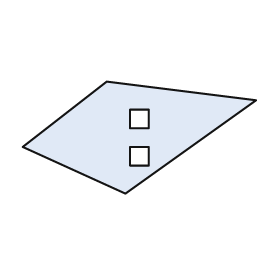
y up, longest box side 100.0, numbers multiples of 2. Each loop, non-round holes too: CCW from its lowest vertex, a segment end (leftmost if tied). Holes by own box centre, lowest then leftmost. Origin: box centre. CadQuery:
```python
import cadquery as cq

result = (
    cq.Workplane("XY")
    .moveTo(-6.0, -24.0)
    .lineTo(50.0, 16.0)
    .lineTo(-14.0, 24.0)
    .lineTo(-50.0, -4.0)
    .close()
    .moveTo(-4.0, -12.0)
    .lineTo(4.0, -12.0)
    .lineTo(4.0, -4.0)
    .lineTo(-4.0, -4.0)
    .close()
    .moveTo(-4.0, 4.0)
    .lineTo(4.0, 4.0)
    .lineTo(4.0, 12.0)
    .lineTo(-4.0, 12.0)
    .close()
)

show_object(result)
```